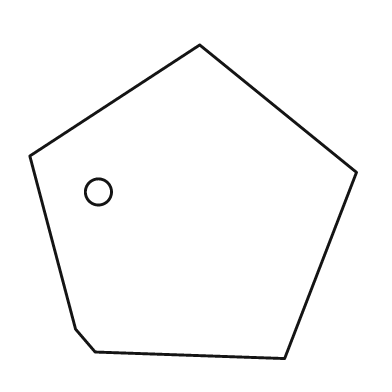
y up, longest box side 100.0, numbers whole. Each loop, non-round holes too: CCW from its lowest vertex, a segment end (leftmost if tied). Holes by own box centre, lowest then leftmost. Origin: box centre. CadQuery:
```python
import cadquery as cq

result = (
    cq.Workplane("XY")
    .moveTo(28.0, -48.0)
    .lineTo(50.0, 9.0)
    .lineTo(2.0, 48.0)
    .lineTo(-50.0, 14.0)
    .lineTo(-36.0, -39.0)
    .lineTo(-30.0, -46.0)
    .close()
    .moveTo(-29.0, 3.0)
    .circle(4.0)
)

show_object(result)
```